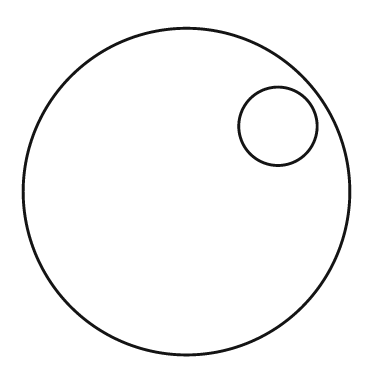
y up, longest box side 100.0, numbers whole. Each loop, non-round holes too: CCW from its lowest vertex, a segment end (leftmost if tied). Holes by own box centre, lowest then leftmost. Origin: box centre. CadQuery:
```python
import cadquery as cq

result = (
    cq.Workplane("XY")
    .moveTo(0.0, 0.0)
    .circle(50.0)
    .moveTo(28.0, 20.0)
    .circle(12.0)
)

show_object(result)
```